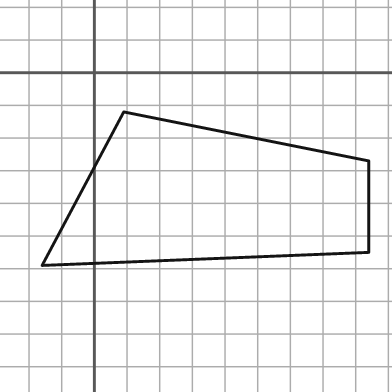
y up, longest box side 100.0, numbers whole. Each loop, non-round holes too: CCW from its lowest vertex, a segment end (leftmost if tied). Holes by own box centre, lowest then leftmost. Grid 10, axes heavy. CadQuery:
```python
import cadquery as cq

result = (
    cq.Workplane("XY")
    .moveTo(-16.0, -59.0)
    .lineTo(84.0, -55.0)
    .lineTo(84.0, -27.0)
    .lineTo(9.0, -12.0)
    .close()
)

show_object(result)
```